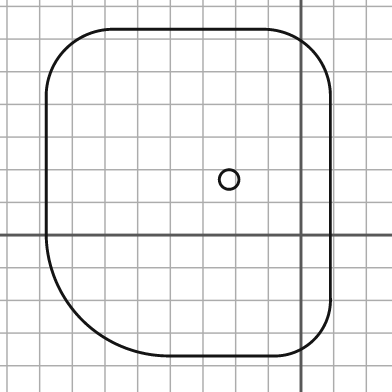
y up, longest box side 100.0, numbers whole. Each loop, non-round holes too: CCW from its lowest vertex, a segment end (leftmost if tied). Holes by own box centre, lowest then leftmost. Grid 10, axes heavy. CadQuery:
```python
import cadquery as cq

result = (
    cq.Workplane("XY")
    .moveTo(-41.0, -37.0)
    .lineTo(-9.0, -37.0)
    .threePointArc((4.0, -32.0), (9.0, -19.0))
    .lineTo(9.0, 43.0)
    .threePointArc((3.0, 57.0), (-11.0, 63.0))
    .lineTo(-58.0, 63.0)
    .threePointArc((-72.0, 57.0), (-78.0, 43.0))
    .lineTo(-78.0, 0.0)
    .threePointArc((-67.0, -26.0), (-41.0, -37.0))
    .close()
    .moveTo(-22.0, 17.0)
    .circle(3.0)
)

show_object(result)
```